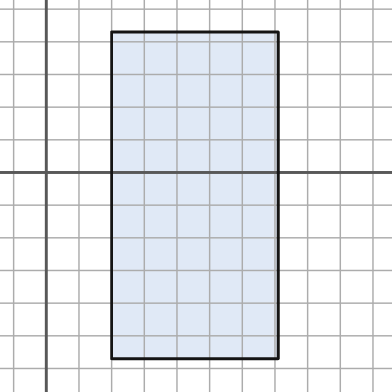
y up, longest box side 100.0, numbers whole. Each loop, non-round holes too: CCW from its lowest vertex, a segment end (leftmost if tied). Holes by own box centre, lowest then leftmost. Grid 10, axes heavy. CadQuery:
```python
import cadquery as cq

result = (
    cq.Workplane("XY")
    .moveTo(20.0, -57.0)
    .lineTo(71.0, -57.0)
    .lineTo(71.0, 43.0)
    .lineTo(20.0, 43.0)
    .close()
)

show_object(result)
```